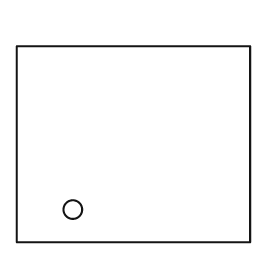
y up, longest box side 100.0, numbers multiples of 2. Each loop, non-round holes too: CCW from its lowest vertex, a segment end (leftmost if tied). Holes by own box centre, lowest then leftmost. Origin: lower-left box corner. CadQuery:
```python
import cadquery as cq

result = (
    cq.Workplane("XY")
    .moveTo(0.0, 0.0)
    .lineTo(100.0, 0.0)
    .lineTo(100.0, 84.0)
    .lineTo(0.0, 84.0)
    .close()
    .moveTo(24.0, 14.0)
    .circle(4.0)
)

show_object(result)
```